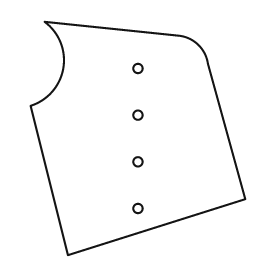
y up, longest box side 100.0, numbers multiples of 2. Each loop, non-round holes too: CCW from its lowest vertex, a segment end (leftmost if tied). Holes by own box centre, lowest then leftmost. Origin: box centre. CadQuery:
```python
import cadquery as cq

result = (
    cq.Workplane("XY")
    .moveTo(-30.0, -50.0)
    .lineTo(46.0, -26.0)
    .lineTo(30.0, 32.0)
    .threePointArc((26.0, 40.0), (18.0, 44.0))
    .lineTo(-40.0, 50.0)
    .threePointArc((-32.0, 30.0), (-46.0, 14.0))
    .close()
    .moveTo(0.0, -30.0)
    .circle(2.0)
    .moveTo(0.0, -10.0)
    .circle(2.0)
    .moveTo(0.0, 10.0)
    .circle(2.0)
    .moveTo(0.0, 30.0)
    .circle(2.0)
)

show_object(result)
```